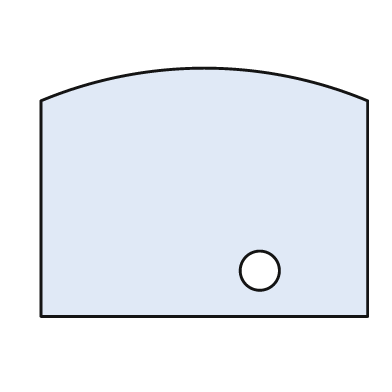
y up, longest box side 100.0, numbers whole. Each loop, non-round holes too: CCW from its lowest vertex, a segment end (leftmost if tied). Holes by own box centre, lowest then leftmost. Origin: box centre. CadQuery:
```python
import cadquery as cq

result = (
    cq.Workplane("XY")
    .moveTo(-50.0, -38.0)
    .lineTo(50.0, -38.0)
    .lineTo(50.0, 28.0)
    .threePointArc((0.0, 38.0), (-50.0, 28.0))
    .close()
    .moveTo(17.0, -24.0)
    .circle(6.0)
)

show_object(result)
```